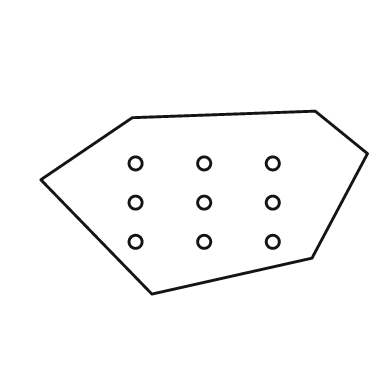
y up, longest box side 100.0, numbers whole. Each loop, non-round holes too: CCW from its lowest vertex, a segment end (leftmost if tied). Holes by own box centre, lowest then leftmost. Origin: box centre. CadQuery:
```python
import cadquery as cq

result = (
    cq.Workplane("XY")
    .moveTo(-16.0, -28.0)
    .lineTo(33.0, -17.0)
    .lineTo(50.0, 15.0)
    .lineTo(34.0, 28.0)
    .lineTo(-22.0, 26.0)
    .lineTo(-50.0, 7.0)
    .close()
    .moveTo(-21.0, -12.0)
    .circle(2.0)
    .moveTo(0.0, -12.0)
    .circle(2.0)
    .moveTo(21.0, -12.0)
    .circle(2.0)
    .moveTo(-21.0, 0.0)
    .circle(2.0)
    .moveTo(0.0, 0.0)
    .circle(2.0)
    .moveTo(21.0, 0.0)
    .circle(2.0)
    .moveTo(-21.0, 12.0)
    .circle(2.0)
    .moveTo(0.0, 12.0)
    .circle(2.0)
    .moveTo(21.0, 12.0)
    .circle(2.0)
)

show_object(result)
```